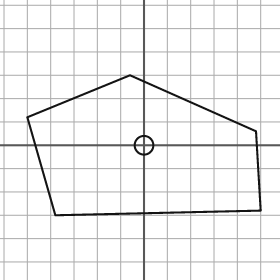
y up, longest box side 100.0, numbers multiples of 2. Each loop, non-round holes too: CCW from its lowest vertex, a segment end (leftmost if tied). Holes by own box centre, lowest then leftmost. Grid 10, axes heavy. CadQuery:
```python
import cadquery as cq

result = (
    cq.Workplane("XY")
    .moveTo(-38.0, -30.0)
    .lineTo(50.0, -28.0)
    .lineTo(48.0, 6.0)
    .lineTo(-6.0, 30.0)
    .lineTo(-50.0, 12.0)
    .close()
    .moveTo(0.0, 0.0)
    .circle(4.0)
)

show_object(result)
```